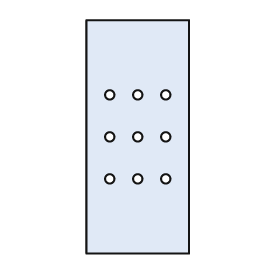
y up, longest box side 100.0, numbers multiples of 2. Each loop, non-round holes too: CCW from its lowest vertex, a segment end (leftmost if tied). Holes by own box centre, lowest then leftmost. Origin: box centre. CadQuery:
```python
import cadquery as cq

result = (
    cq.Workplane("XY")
    .moveTo(-22.0, -50.0)
    .lineTo(22.0, -50.0)
    .lineTo(22.0, 50.0)
    .lineTo(-22.0, 50.0)
    .close()
    .moveTo(-12.0, -18.0)
    .circle(2.0)
    .moveTo(0.0, -18.0)
    .circle(2.0)
    .moveTo(12.0, -18.0)
    .circle(2.0)
    .moveTo(-12.0, 0.0)
    .circle(2.0)
    .moveTo(0.0, 0.0)
    .circle(2.0)
    .moveTo(12.0, 0.0)
    .circle(2.0)
    .moveTo(-12.0, 18.0)
    .circle(2.0)
    .moveTo(0.0, 18.0)
    .circle(2.0)
    .moveTo(12.0, 18.0)
    .circle(2.0)
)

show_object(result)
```